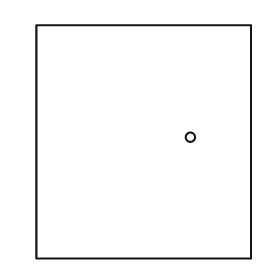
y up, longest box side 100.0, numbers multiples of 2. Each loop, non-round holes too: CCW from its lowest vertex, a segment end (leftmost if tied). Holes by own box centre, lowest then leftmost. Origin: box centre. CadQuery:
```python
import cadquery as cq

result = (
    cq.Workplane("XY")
    .moveTo(-46.0, -50.0)
    .lineTo(46.0, -50.0)
    .lineTo(46.0, 50.0)
    .lineTo(-46.0, 50.0)
    .close()
    .moveTo(20.0, 2.0)
    .circle(2.0)
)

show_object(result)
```